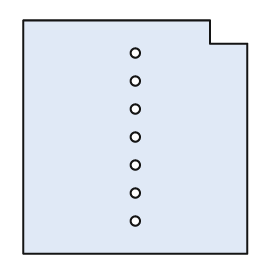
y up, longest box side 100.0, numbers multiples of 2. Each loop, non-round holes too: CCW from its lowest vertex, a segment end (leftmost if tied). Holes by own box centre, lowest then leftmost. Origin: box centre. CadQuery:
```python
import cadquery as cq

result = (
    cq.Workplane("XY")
    .moveTo(-48.0, -50.0)
    .lineTo(48.0, -50.0)
    .lineTo(48.0, 40.0)
    .lineTo(32.0, 40.0)
    .lineTo(32.0, 50.0)
    .lineTo(-48.0, 50.0)
    .close()
    .moveTo(0.0, -36.0)
    .circle(2.0)
    .moveTo(0.0, -24.0)
    .circle(2.0)
    .moveTo(0.0, -12.0)
    .circle(2.0)
    .moveTo(0.0, 0.0)
    .circle(2.0)
    .moveTo(0.0, 12.0)
    .circle(2.0)
    .moveTo(0.0, 24.0)
    .circle(2.0)
    .moveTo(0.0, 36.0)
    .circle(2.0)
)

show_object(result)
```